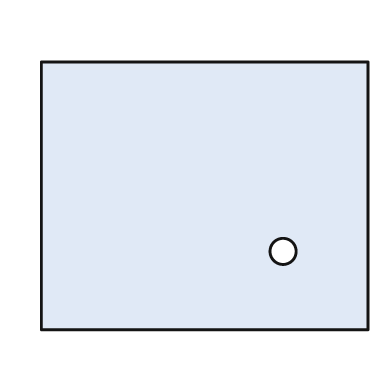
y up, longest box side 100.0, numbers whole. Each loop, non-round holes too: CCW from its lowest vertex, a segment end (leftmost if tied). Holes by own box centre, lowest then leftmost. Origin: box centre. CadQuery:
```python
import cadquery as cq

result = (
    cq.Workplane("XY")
    .moveTo(-50.0, -41.0)
    .lineTo(50.0, -41.0)
    .lineTo(50.0, 41.0)
    .lineTo(-50.0, 41.0)
    .close()
    .moveTo(24.0, -17.0)
    .circle(4.0)
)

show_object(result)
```